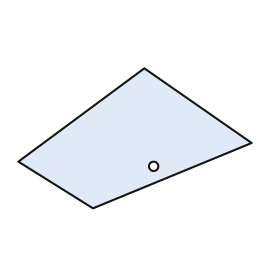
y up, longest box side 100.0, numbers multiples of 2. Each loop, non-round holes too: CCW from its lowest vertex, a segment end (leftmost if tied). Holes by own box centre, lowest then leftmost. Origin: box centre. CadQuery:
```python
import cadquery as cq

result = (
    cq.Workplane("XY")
    .moveTo(-18.0, -30.0)
    .lineTo(50.0, -2.0)
    .lineTo(4.0, 30.0)
    .lineTo(-50.0, -10.0)
    .close()
    .moveTo(8.0, -12.0)
    .circle(2.0)
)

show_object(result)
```